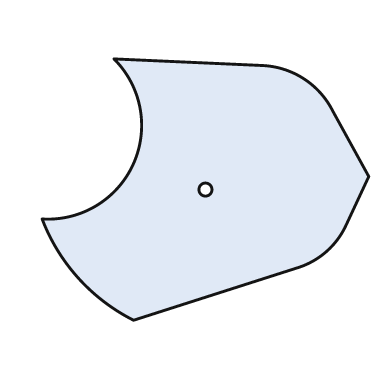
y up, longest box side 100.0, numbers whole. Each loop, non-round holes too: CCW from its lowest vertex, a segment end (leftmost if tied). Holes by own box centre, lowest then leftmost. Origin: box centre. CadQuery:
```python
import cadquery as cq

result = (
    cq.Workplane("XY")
    .moveTo(-22.0, -40.0)
    .lineTo(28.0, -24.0)
    .threePointArc((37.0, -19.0), (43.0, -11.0))
    .lineTo(50.0, 4.0)
    .lineTo(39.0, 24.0)
    .threePointArc((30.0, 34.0), (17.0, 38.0))
    .lineTo(-28.0, 40.0)
    .threePointArc((-22.0, 8.0), (-50.0, -9.0))
    .threePointArc((-39.0, -27.0), (-22.0, -40.0))
    .close()
    .moveTo(0.0, 0.0)
    .circle(2.0)
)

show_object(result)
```